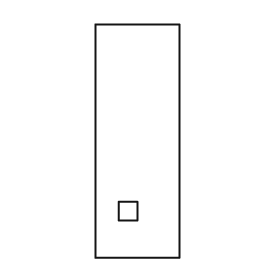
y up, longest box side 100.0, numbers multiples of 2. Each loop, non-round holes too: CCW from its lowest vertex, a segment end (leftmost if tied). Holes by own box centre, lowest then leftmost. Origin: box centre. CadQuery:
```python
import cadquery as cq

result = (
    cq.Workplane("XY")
    .moveTo(-18.0, -50.0)
    .lineTo(18.0, -50.0)
    .lineTo(18.0, 50.0)
    .lineTo(-18.0, 50.0)
    .close()
    .moveTo(-8.0, -34.0)
    .lineTo(0.0, -34.0)
    .lineTo(0.0, -26.0)
    .lineTo(-8.0, -26.0)
    .close()
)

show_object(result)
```